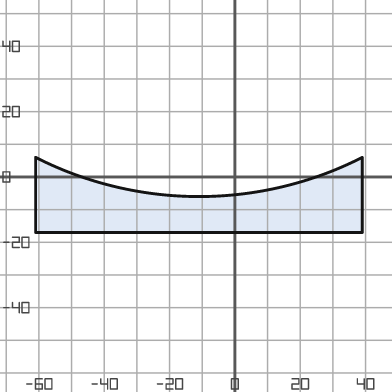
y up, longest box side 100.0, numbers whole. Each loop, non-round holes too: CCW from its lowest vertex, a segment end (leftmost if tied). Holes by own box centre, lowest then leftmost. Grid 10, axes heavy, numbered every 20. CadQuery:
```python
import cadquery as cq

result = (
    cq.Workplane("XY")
    .moveTo(-61.0, -17.0)
    .lineTo(39.0, -17.0)
    .lineTo(39.0, 6.0)
    .threePointArc((-11.0, -6.0), (-61.0, 6.0))
    .close()
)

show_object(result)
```